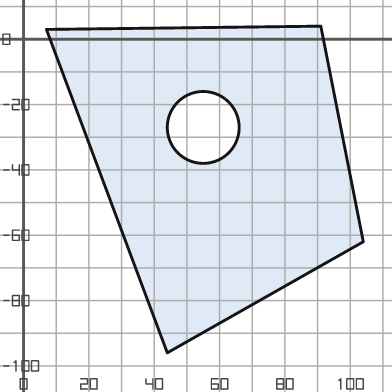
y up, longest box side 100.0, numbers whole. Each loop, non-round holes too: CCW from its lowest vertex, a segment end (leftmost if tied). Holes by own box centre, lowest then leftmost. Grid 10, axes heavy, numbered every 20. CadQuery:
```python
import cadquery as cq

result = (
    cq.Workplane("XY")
    .moveTo(44.0, -96.0)
    .lineTo(104.0, -62.0)
    .lineTo(91.0, 4.0)
    .lineTo(7.0, 3.0)
    .close()
    .moveTo(55.0, -27.0)
    .circle(11.0)
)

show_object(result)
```